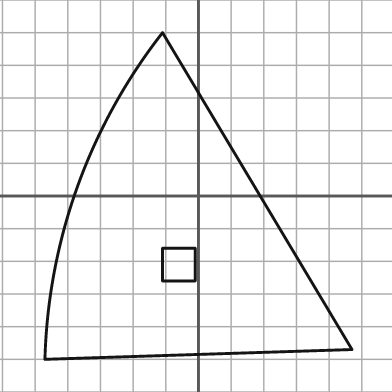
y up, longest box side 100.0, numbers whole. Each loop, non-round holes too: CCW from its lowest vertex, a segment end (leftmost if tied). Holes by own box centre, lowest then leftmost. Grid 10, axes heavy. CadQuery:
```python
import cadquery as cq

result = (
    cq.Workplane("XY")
    .moveTo(-47.0, -50.0)
    .lineTo(47.0, -47.0)
    .lineTo(-11.0, 50.0)
    .threePointArc((-37.0, 3.0), (-47.0, -50.0))
    .close()
    .moveTo(-11.0, -26.0)
    .lineTo(-1.0, -26.0)
    .lineTo(-1.0, -16.0)
    .lineTo(-11.0, -16.0)
    .close()
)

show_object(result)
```